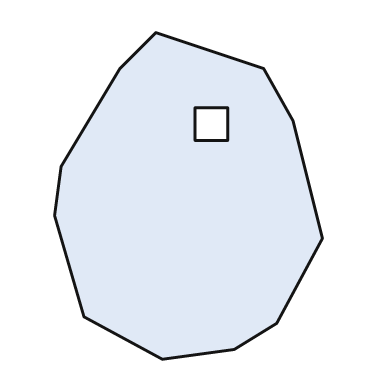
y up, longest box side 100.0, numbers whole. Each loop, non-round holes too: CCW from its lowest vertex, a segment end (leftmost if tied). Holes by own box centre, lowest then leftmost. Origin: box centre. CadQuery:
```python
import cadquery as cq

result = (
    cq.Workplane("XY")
    .moveTo(-8.0, -50.0)
    .lineTo(14.0, -47.0)
    .lineTo(27.0, -39.0)
    .lineTo(41.0, -13.0)
    .lineTo(32.0, 23.0)
    .lineTo(23.0, 39.0)
    .lineTo(-10.0, 50.0)
    .lineTo(-21.0, 39.0)
    .lineTo(-39.0, 9.0)
    .lineTo(-41.0, -6.0)
    .lineTo(-32.0, -37.0)
    .close()
    .moveTo(2.0, 17.0)
    .lineTo(12.0, 17.0)
    .lineTo(12.0, 27.0)
    .lineTo(2.0, 27.0)
    .close()
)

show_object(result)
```